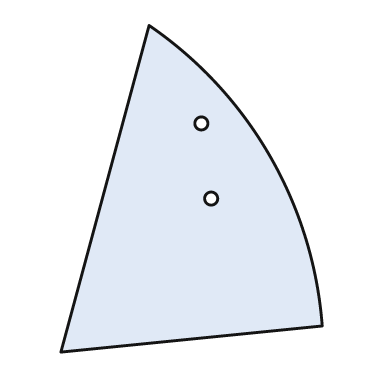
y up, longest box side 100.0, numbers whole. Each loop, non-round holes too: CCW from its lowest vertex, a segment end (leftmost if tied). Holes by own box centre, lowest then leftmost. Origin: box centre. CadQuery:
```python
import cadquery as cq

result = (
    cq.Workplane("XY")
    .moveTo(-40.0, -50.0)
    .lineTo(40.0, -42.0)
    .threePointArc((24.0, 10.0), (-13.0, 50.0))
    .close()
    .moveTo(6.0, -3.0)
    .circle(2.0)
    .moveTo(3.0, 20.0)
    .circle(2.0)
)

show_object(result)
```